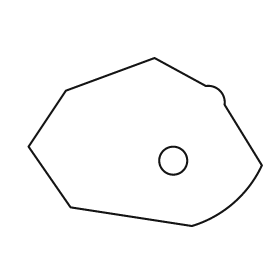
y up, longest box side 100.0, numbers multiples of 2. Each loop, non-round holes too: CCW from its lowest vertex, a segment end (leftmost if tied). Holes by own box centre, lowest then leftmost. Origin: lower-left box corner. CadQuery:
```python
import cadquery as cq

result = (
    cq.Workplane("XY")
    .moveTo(70.0, 0.0)
    .threePointArc((88.0, 10.0), (100.0, 26.0))
    .lineTo(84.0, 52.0)
    .threePointArc((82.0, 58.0), (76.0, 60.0))
    .lineTo(54.0, 72.0)
    .lineTo(16.0, 58.0)
    .lineTo(0.0, 34.0)
    .lineTo(18.0, 8.0)
    .close()
    .moveTo(62.0, 28.0)
    .circle(6.0)
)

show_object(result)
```